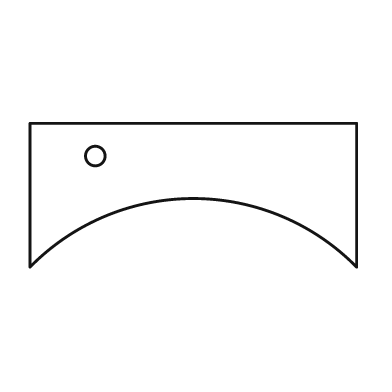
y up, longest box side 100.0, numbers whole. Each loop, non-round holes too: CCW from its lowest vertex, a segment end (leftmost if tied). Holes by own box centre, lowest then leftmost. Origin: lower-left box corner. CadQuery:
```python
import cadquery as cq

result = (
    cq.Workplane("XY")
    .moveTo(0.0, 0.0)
    .threePointArc((50.0, 21.0), (100.0, 0.0))
    .lineTo(100.0, 44.0)
    .lineTo(0.0, 44.0)
    .close()
    .moveTo(20.0, 34.0)
    .circle(3.0)
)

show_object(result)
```